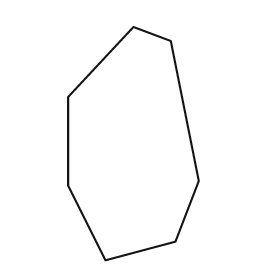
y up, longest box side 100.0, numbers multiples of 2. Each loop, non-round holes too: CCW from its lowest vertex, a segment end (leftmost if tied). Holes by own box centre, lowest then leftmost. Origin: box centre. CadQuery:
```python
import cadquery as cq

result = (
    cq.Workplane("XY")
    .moveTo(-12.0, -50.0)
    .lineTo(18.0, -42.0)
    .lineTo(28.0, -16.0)
    .lineTo(16.0, 44.0)
    .lineTo(0.0, 50.0)
    .lineTo(-28.0, 20.0)
    .lineTo(-28.0, -18.0)
    .close()
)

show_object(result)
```